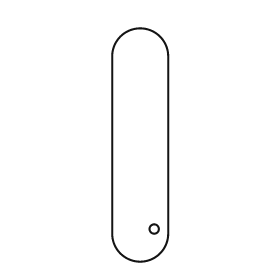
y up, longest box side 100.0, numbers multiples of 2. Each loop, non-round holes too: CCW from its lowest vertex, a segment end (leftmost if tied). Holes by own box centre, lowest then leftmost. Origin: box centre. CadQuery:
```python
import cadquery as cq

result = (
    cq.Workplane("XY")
    .moveTo(-12.0, -38.0)
    .threePointArc((0.0, -50.0), (12.0, -38.0))
    .lineTo(12.0, 38.0)
    .threePointArc((0.0, 50.0), (-12.0, 38.0))
    .close()
    .moveTo(6.0, -36.0)
    .circle(2.0)
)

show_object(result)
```